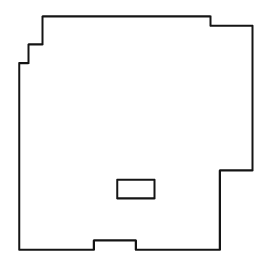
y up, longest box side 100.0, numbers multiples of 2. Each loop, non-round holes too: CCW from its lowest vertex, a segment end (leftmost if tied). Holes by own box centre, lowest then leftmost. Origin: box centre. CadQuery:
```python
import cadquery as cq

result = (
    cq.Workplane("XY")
    .moveTo(-50.0, -50.0)
    .lineTo(-18.0, -50.0)
    .lineTo(-18.0, -46.0)
    .lineTo(0.0, -46.0)
    .lineTo(0.0, -50.0)
    .lineTo(36.0, -50.0)
    .lineTo(36.0, -16.0)
    .lineTo(50.0, -16.0)
    .lineTo(50.0, 46.0)
    .lineTo(32.0, 46.0)
    .lineTo(32.0, 50.0)
    .lineTo(-40.0, 50.0)
    .lineTo(-40.0, 38.0)
    .lineTo(-46.0, 38.0)
    .lineTo(-46.0, 30.0)
    .lineTo(-50.0, 30.0)
    .close()
    .moveTo(-8.0, -28.0)
    .lineTo(8.0, -28.0)
    .lineTo(8.0, -20.0)
    .lineTo(-8.0, -20.0)
    .close()
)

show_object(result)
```